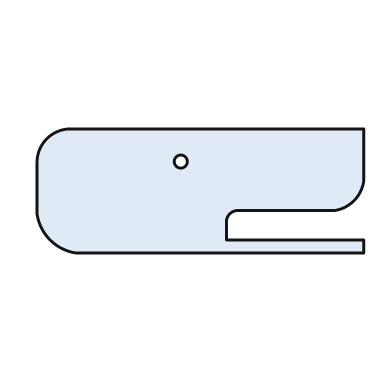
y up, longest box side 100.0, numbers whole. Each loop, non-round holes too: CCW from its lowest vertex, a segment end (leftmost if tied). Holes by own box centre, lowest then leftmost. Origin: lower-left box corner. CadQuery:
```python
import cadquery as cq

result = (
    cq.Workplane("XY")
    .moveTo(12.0, 0.0)
    .lineTo(100.0, 0.0)
    .lineTo(100.0, 4.0)
    .lineTo(58.0, 4.0)
    .lineTo(58.0, 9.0)
    .threePointArc((59.0, 12.0), (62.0, 13.0))
    .lineTo(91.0, 13.0)
    .threePointArc((97.0, 16.0), (100.0, 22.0))
    .lineTo(100.0, 38.0)
    .lineTo(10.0, 38.0)
    .threePointArc((3.0, 35.0), (0.0, 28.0))
    .lineTo(0.0, 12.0)
    .threePointArc((4.0, 4.0), (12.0, 0.0))
    .close()
    .moveTo(44.0, 28.0)
    .circle(2.0)
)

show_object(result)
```